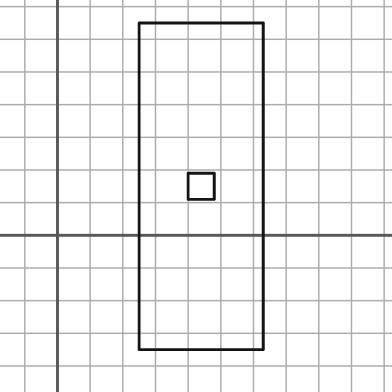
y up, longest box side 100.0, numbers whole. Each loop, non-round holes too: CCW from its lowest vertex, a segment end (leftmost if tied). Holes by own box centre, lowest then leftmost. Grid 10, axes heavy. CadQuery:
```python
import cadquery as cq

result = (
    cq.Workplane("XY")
    .moveTo(25.0, -35.0)
    .lineTo(63.0, -35.0)
    .lineTo(63.0, 65.0)
    .lineTo(25.0, 65.0)
    .close()
    .moveTo(40.0, 11.0)
    .lineTo(48.0, 11.0)
    .lineTo(48.0, 19.0)
    .lineTo(40.0, 19.0)
    .close()
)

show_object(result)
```